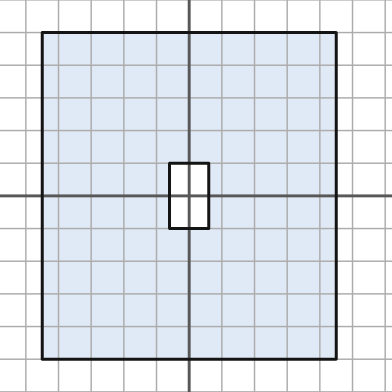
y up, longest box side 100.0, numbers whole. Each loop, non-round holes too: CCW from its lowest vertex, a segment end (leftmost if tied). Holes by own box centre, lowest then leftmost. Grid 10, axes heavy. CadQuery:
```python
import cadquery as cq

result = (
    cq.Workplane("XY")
    .moveTo(-45.0, -50.0)
    .lineTo(45.0, -50.0)
    .lineTo(45.0, 50.0)
    .lineTo(-45.0, 50.0)
    .close()
    .moveTo(-6.0, -10.0)
    .lineTo(6.0, -10.0)
    .lineTo(6.0, 10.0)
    .lineTo(-6.0, 10.0)
    .close()
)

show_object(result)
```